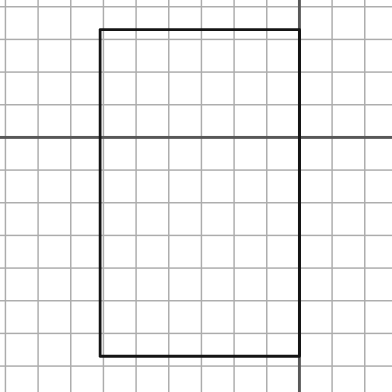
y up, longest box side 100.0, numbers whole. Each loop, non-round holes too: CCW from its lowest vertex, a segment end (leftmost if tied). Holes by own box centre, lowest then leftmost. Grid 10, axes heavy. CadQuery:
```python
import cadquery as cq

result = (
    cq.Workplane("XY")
    .moveTo(-61.0, -67.0)
    .lineTo(0.0, -67.0)
    .lineTo(0.0, 33.0)
    .lineTo(-61.0, 33.0)
    .close()
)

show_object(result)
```